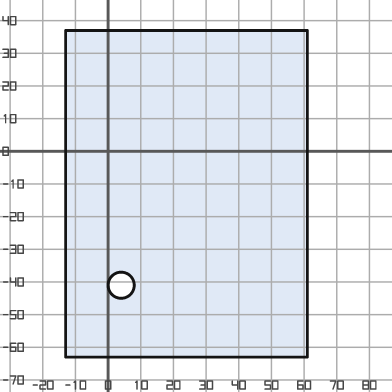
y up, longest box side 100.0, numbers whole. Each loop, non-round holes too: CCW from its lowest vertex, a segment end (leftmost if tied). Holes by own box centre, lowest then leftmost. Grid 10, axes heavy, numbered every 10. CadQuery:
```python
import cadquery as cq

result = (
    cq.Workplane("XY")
    .moveTo(-13.0, -63.0)
    .lineTo(61.0, -63.0)
    .lineTo(61.0, 37.0)
    .lineTo(-13.0, 37.0)
    .close()
    .moveTo(4.0, -41.0)
    .circle(4.0)
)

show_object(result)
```